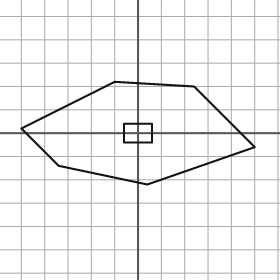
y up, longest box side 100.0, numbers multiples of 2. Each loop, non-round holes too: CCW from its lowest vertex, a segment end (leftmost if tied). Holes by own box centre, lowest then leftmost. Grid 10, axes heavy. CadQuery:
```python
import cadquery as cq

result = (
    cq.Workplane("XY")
    .moveTo(4.0, -22.0)
    .lineTo(50.0, -6.0)
    .lineTo(24.0, 20.0)
    .lineTo(-10.0, 22.0)
    .lineTo(-50.0, 2.0)
    .lineTo(-34.0, -14.0)
    .close()
    .moveTo(-6.0, -4.0)
    .lineTo(6.0, -4.0)
    .lineTo(6.0, 4.0)
    .lineTo(-6.0, 4.0)
    .close()
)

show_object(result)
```